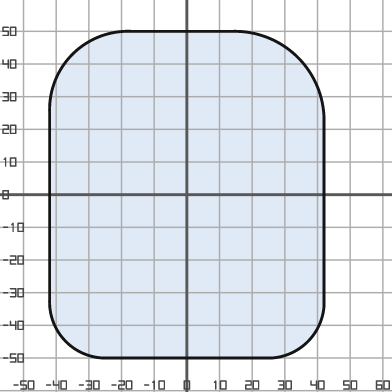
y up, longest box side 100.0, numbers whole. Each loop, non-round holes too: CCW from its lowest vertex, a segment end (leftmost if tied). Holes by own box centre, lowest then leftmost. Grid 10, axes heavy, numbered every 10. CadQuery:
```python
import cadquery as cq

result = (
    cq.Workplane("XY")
    .moveTo(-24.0, -50.0)
    .lineTo(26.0, -50.0)
    .threePointArc((37.0, -45.0), (42.0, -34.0))
    .lineTo(42.0, 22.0)
    .threePointArc((34.0, 42.0), (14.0, 50.0))
    .lineTo(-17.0, 50.0)
    .threePointArc((-35.0, 43.0), (-42.0, 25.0))
    .lineTo(-42.0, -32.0)
    .threePointArc((-37.0, -45.0), (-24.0, -50.0))
    .close()
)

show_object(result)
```